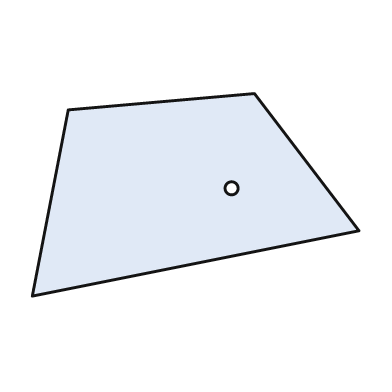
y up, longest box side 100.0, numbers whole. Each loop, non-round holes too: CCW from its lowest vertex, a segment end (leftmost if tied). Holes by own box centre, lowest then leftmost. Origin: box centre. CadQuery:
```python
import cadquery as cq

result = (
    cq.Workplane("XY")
    .moveTo(-50.0, -31.0)
    .lineTo(50.0, -11.0)
    .lineTo(18.0, 31.0)
    .lineTo(-39.0, 26.0)
    .close()
    .moveTo(11.0, 2.0)
    .circle(2.0)
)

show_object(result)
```